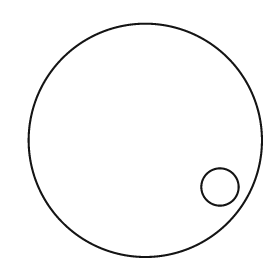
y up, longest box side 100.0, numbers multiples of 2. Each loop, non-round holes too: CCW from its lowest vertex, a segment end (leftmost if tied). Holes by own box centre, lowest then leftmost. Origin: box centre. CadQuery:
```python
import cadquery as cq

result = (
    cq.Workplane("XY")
    .moveTo(0.0, 0.0)
    .circle(50.0)
    .moveTo(32.0, -20.0)
    .circle(8.0)
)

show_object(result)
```